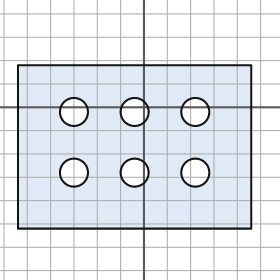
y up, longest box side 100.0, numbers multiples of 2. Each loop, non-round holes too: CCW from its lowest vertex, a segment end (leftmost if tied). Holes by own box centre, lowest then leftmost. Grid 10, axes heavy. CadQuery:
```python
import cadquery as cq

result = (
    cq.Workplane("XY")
    .moveTo(-54.0, -52.0)
    .lineTo(46.0, -52.0)
    .lineTo(46.0, 18.0)
    .lineTo(-54.0, 18.0)
    .close()
    .moveTo(-30.0, -28.0)
    .circle(6.0)
    .moveTo(-4.0, -28.0)
    .circle(6.0)
    .moveTo(22.0, -28.0)
    .circle(6.0)
    .moveTo(-30.0, -2.0)
    .circle(6.0)
    .moveTo(-4.0, -2.0)
    .circle(6.0)
    .moveTo(22.0, -2.0)
    .circle(6.0)
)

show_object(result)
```